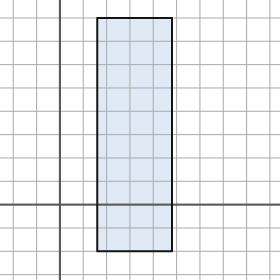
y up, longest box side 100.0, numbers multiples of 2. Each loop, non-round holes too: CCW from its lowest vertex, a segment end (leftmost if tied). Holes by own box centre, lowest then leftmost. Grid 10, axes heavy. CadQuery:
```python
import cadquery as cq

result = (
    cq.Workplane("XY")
    .moveTo(16.0, -20.0)
    .lineTo(48.0, -20.0)
    .lineTo(48.0, 80.0)
    .lineTo(16.0, 80.0)
    .close()
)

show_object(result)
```